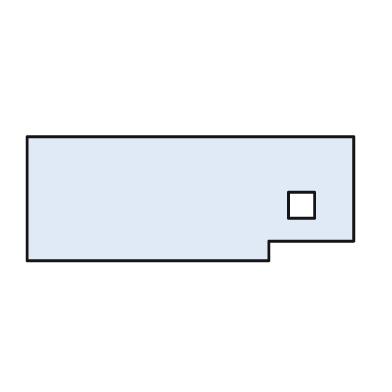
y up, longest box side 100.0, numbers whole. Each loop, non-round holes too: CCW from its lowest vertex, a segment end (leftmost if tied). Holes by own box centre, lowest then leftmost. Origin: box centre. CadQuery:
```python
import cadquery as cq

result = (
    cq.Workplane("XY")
    .moveTo(-50.0, -19.0)
    .lineTo(24.0, -19.0)
    .lineTo(24.0, -13.0)
    .lineTo(50.0, -13.0)
    .lineTo(50.0, 19.0)
    .lineTo(-50.0, 19.0)
    .close()
    .moveTo(30.0, -6.0)
    .lineTo(38.0, -6.0)
    .lineTo(38.0, 2.0)
    .lineTo(30.0, 2.0)
    .close()
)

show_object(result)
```